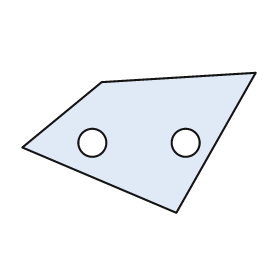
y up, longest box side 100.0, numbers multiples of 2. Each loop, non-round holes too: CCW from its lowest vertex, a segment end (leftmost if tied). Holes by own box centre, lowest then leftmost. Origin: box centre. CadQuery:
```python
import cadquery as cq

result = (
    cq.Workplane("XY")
    .moveTo(16.0, -30.0)
    .lineTo(50.0, 30.0)
    .lineTo(-16.0, 26.0)
    .lineTo(-50.0, -2.0)
    .close()
    .moveTo(-20.0, 0.0)
    .circle(6.0)
    .moveTo(20.0, 0.0)
    .circle(6.0)
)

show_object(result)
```